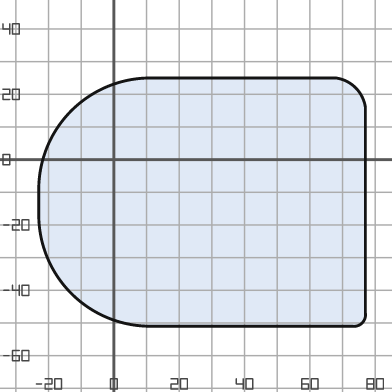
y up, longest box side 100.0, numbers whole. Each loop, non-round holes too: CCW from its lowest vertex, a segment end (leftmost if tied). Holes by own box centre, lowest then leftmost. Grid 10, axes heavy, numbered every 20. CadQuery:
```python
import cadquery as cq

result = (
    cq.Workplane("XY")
    .moveTo(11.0, -51.0)
    .lineTo(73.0, -51.0)
    .threePointArc((76.0, -50.0), (77.0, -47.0))
    .lineTo(77.0, 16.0)
    .threePointArc((74.0, 22.0), (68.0, 25.0))
    .lineTo(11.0, 25.0)
    .threePointArc((-13.0, 15.0), (-23.0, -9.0))
    .lineTo(-23.0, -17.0)
    .threePointArc((-13.0, -41.0), (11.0, -51.0))
    .close()
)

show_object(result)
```